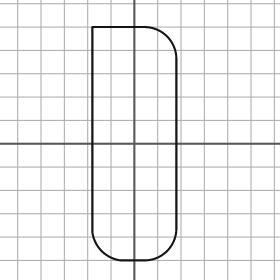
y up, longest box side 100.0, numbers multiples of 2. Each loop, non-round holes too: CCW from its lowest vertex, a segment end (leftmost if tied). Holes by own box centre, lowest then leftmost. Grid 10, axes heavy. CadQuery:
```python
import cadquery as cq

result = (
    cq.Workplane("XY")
    .moveTo(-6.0, -50.0)
    .lineTo(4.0, -50.0)
    .threePointArc((14.0, -46.0), (18.0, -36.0))
    .lineTo(18.0, 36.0)
    .threePointArc((14.0, 46.0), (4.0, 50.0))
    .lineTo(-18.0, 50.0)
    .lineTo(-18.0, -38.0)
    .threePointArc((-14.0, -46.0), (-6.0, -50.0))
    .close()
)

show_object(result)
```